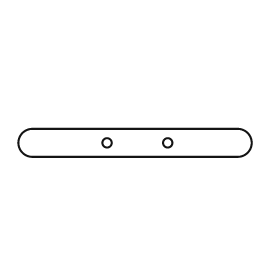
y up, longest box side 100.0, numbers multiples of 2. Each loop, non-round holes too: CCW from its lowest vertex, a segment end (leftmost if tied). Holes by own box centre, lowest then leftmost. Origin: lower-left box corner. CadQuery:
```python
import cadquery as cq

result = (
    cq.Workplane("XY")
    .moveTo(6.0, 0.0)
    .lineTo(94.0, 0.0)
    .threePointArc((100.0, 6.0), (94.0, 12.0))
    .lineTo(6.0, 12.0)
    .threePointArc((0.0, 6.0), (6.0, 0.0))
    .close()
    .moveTo(38.0, 6.0)
    .circle(2.0)
    .moveTo(64.0, 6.0)
    .circle(2.0)
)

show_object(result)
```